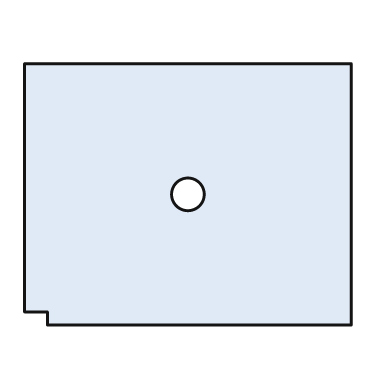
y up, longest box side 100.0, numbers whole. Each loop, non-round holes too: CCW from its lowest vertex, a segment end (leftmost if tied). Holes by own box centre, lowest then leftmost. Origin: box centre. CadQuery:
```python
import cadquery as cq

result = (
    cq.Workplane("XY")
    .moveTo(-43.0, -40.0)
    .lineTo(50.0, -40.0)
    .lineTo(50.0, 40.0)
    .lineTo(-50.0, 40.0)
    .lineTo(-50.0, -36.0)
    .lineTo(-43.0, -36.0)
    .close()
    .moveTo(0.0, 0.0)
    .circle(5.0)
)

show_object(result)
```